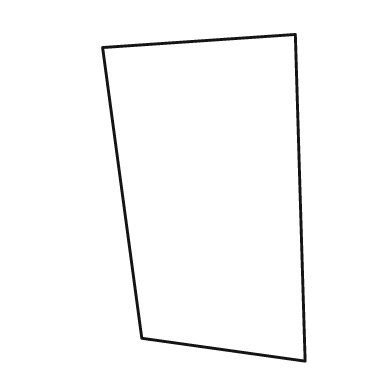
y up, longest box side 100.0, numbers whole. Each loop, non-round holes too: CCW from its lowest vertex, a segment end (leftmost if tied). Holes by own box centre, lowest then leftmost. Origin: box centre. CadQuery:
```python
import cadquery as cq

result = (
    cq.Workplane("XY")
    .moveTo(31.0, -50.0)
    .lineTo(28.0, 50.0)
    .lineTo(-31.0, 46.0)
    .lineTo(-19.0, -43.0)
    .close()
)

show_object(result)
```